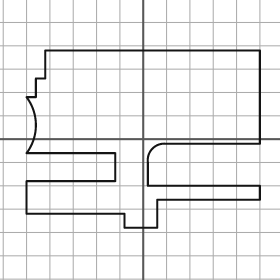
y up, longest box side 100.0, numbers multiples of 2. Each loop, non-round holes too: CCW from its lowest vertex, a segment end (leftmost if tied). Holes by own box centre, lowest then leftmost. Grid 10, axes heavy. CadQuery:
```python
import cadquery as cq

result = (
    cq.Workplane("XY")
    .moveTo(-8.0, -38.0)
    .lineTo(6.0, -38.0)
    .lineTo(6.0, -26.0)
    .lineTo(50.0, -26.0)
    .lineTo(50.0, -20.0)
    .lineTo(2.0, -20.0)
    .lineTo(2.0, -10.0)
    .threePointArc((4.0, -4.0), (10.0, -2.0))
    .lineTo(50.0, -2.0)
    .lineTo(50.0, 38.0)
    .lineTo(-42.0, 38.0)
    .lineTo(-42.0, 26.0)
    .lineTo(-46.0, 26.0)
    .lineTo(-46.0, 18.0)
    .lineTo(-50.0, 18.0)
    .threePointArc((-46.0, 6.0), (-50.0, -6.0))
    .lineTo(-12.0, -6.0)
    .lineTo(-12.0, -18.0)
    .lineTo(-50.0, -18.0)
    .lineTo(-50.0, -32.0)
    .lineTo(-8.0, -32.0)
    .close()
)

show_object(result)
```